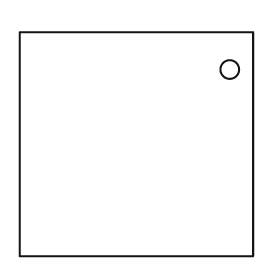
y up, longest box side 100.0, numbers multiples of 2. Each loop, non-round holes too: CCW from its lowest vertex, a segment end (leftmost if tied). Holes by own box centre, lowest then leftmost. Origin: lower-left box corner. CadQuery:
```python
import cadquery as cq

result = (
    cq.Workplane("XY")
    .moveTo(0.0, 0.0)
    .lineTo(100.0, 0.0)
    .lineTo(100.0, 96.0)
    .lineTo(0.0, 96.0)
    .close()
    .moveTo(90.0, 80.0)
    .circle(4.0)
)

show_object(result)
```